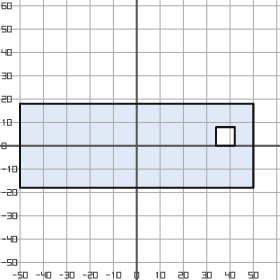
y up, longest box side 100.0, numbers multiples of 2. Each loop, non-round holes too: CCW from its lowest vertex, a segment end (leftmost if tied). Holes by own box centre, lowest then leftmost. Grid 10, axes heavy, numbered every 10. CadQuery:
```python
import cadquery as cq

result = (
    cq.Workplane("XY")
    .moveTo(-50.0, -18.0)
    .lineTo(50.0, -18.0)
    .lineTo(50.0, 18.0)
    .lineTo(-50.0, 18.0)
    .close()
    .moveTo(34.0, 0.0)
    .lineTo(42.0, 0.0)
    .lineTo(42.0, 8.0)
    .lineTo(34.0, 8.0)
    .close()
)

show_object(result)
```